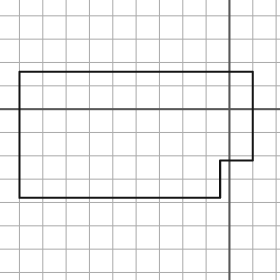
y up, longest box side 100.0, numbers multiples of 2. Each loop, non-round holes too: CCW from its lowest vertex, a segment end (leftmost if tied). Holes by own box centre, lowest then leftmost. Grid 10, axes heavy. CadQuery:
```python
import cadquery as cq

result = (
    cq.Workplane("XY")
    .moveTo(-90.0, -38.0)
    .lineTo(-4.0, -38.0)
    .lineTo(-4.0, -22.0)
    .lineTo(10.0, -22.0)
    .lineTo(10.0, 16.0)
    .lineTo(-90.0, 16.0)
    .close()
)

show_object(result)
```